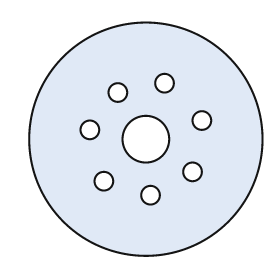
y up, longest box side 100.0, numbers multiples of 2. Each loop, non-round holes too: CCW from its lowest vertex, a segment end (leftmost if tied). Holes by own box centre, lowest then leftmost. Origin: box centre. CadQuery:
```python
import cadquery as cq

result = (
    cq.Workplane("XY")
    .moveTo(0.0, 0.0)
    .circle(50.0)
    .moveTo(2.0, -24.0)
    .circle(4.0)
    .moveTo(-18.0, -18.0)
    .circle(4.0)
    .moveTo(20.0, -14.0)
    .circle(4.0)
    .moveTo(0.0, 0.0)
    .circle(10.0)
    .moveTo(-24.0, 4.0)
    .circle(4.0)
    .moveTo(24.0, 8.0)
    .circle(4.0)
    .moveTo(-12.0, 20.0)
    .circle(4.0)
    .moveTo(8.0, 24.0)
    .circle(4.0)
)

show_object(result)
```